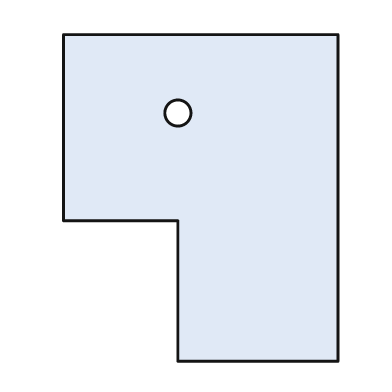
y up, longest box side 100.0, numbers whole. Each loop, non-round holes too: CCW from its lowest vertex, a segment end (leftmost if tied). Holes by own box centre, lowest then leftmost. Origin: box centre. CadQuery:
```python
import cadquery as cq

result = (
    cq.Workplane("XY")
    .moveTo(-7.0, -50.0)
    .lineTo(42.0, -50.0)
    .lineTo(42.0, 50.0)
    .lineTo(-42.0, 50.0)
    .lineTo(-42.0, -7.0)
    .lineTo(-7.0, -7.0)
    .close()
    .moveTo(-7.0, 26.0)
    .circle(4.0)
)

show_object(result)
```